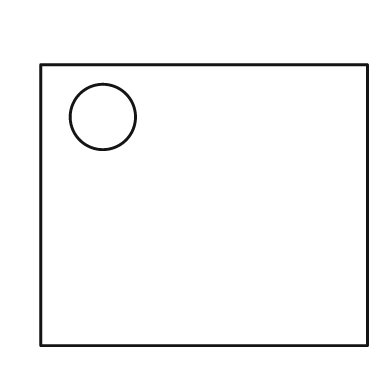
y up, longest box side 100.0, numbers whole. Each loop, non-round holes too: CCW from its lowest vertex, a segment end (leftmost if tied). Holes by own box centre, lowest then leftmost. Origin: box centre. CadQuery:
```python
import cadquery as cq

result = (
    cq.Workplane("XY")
    .moveTo(-50.0, -43.0)
    .lineTo(50.0, -43.0)
    .lineTo(50.0, 43.0)
    .lineTo(-50.0, 43.0)
    .close()
    .moveTo(-31.0, 27.0)
    .circle(10.0)
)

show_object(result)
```